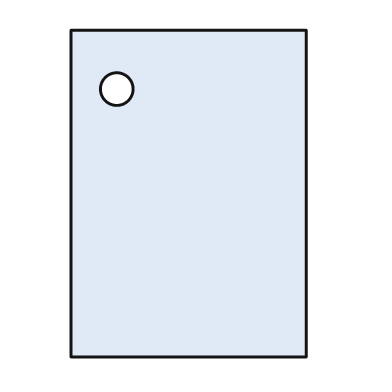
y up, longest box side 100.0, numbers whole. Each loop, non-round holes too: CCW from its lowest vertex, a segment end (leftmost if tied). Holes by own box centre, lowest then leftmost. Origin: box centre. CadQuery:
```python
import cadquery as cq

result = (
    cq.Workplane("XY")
    .moveTo(-36.0, -50.0)
    .lineTo(36.0, -50.0)
    .lineTo(36.0, 50.0)
    .lineTo(-36.0, 50.0)
    .close()
    .moveTo(-22.0, 32.0)
    .circle(5.0)
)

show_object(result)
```